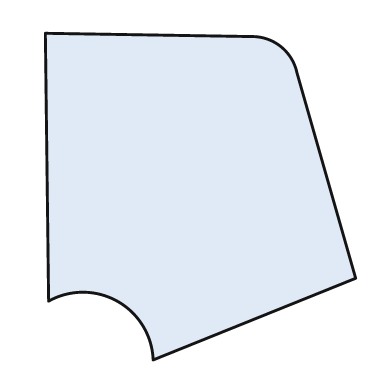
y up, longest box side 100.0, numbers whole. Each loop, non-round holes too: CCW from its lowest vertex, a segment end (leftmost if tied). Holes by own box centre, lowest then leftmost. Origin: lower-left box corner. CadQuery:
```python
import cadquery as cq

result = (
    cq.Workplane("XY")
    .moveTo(33.0, 0.0)
    .lineTo(95.0, 25.0)
    .lineTo(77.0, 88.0)
    .threePointArc((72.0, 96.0), (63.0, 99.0))
    .lineTo(0.0, 100.0)
    .lineTo(1.0, 18.0)
    .threePointArc((22.0, 18.0), (33.0, 0.0))
    .close()
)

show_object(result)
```